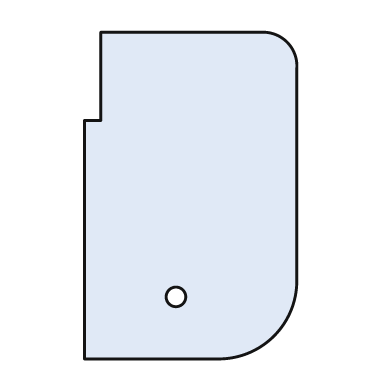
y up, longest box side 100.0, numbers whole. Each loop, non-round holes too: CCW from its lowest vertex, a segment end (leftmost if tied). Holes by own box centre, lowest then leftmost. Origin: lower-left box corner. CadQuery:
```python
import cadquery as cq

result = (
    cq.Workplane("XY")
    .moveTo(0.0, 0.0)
    .lineTo(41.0, 0.0)
    .threePointArc((58.0, 7.0), (65.0, 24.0))
    .lineTo(65.0, 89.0)
    .threePointArc((62.0, 97.0), (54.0, 100.0))
    .lineTo(5.0, 100.0)
    .lineTo(5.0, 73.0)
    .lineTo(0.0, 73.0)
    .close()
    .moveTo(28.0, 19.0)
    .circle(3.0)
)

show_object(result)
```